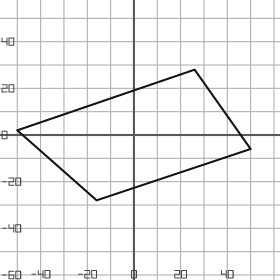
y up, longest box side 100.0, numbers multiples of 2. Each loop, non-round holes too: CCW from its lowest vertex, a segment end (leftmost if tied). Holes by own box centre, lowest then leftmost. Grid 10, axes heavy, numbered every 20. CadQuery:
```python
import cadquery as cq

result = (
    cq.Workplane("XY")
    .moveTo(-16.0, -28.0)
    .lineTo(50.0, -6.0)
    .lineTo(26.0, 28.0)
    .lineTo(-50.0, 2.0)
    .close()
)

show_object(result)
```